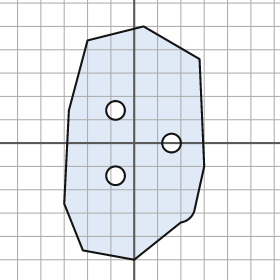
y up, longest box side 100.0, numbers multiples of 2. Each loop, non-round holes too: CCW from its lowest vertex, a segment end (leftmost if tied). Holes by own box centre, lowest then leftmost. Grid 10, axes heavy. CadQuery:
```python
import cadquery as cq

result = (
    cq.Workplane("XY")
    .moveTo(0.0, -50.0)
    .lineTo(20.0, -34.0)
    .threePointArc((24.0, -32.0), (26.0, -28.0))
    .lineTo(30.0, -10.0)
    .lineTo(28.0, 36.0)
    .lineTo(4.0, 50.0)
    .lineTo(-20.0, 44.0)
    .lineTo(-28.0, 14.0)
    .lineTo(-30.0, -26.0)
    .lineTo(-22.0, -46.0)
    .close()
    .moveTo(-8.0, -14.0)
    .circle(4.0)
    .moveTo(16.0, 0.0)
    .circle(4.0)
    .moveTo(-8.0, 14.0)
    .circle(4.0)
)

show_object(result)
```